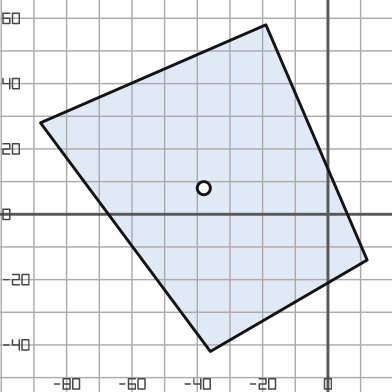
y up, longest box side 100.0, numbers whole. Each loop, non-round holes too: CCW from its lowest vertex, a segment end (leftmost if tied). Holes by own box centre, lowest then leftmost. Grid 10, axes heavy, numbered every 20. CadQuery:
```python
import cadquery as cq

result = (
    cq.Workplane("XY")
    .moveTo(-36.0, -42.0)
    .lineTo(12.0, -14.0)
    .lineTo(-19.0, 58.0)
    .lineTo(-88.0, 28.0)
    .close()
    .moveTo(-38.0, 8.0)
    .circle(2.0)
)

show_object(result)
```